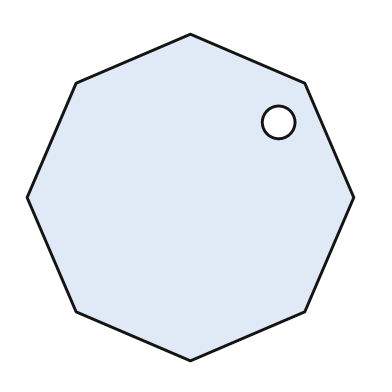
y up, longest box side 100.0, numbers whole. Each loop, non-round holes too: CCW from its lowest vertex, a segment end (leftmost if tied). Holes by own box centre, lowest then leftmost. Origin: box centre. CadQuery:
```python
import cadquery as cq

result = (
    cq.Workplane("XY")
    .moveTo(0.0, -50.0)
    .lineTo(35.0, -35.0)
    .lineTo(50.0, 0.0)
    .lineTo(35.0, 35.0)
    .lineTo(0.0, 50.0)
    .lineTo(-35.0, 35.0)
    .lineTo(-50.0, 0.0)
    .lineTo(-35.0, -35.0)
    .close()
    .moveTo(27.0, 23.0)
    .circle(5.0)
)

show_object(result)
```